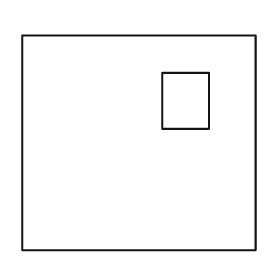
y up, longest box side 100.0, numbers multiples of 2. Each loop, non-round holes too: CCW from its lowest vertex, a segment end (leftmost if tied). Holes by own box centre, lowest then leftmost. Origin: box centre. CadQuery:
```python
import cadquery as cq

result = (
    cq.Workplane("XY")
    .moveTo(-50.0, -46.0)
    .lineTo(50.0, -46.0)
    .lineTo(50.0, 46.0)
    .lineTo(-50.0, 46.0)
    .close()
    .moveTo(10.0, 6.0)
    .lineTo(30.0, 6.0)
    .lineTo(30.0, 30.0)
    .lineTo(10.0, 30.0)
    .close()
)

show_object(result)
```